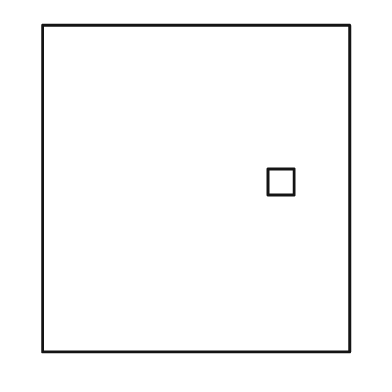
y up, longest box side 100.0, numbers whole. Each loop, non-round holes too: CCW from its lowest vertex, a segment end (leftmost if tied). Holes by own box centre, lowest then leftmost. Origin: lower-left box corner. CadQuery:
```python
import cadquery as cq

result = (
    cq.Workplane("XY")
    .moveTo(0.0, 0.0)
    .lineTo(94.0, 0.0)
    .lineTo(94.0, 100.0)
    .lineTo(0.0, 100.0)
    .close()
    .moveTo(69.0, 48.0)
    .lineTo(77.0, 48.0)
    .lineTo(77.0, 56.0)
    .lineTo(69.0, 56.0)
    .close()
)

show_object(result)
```